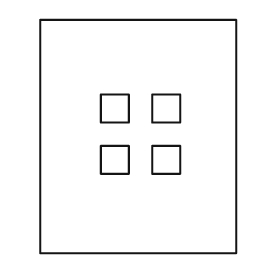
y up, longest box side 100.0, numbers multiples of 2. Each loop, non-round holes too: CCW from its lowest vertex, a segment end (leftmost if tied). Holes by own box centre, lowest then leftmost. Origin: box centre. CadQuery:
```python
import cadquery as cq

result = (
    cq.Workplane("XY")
    .moveTo(-42.0, -50.0)
    .lineTo(42.0, -50.0)
    .lineTo(42.0, 50.0)
    .lineTo(-42.0, 50.0)
    .close()
    .moveTo(-16.0, -16.0)
    .lineTo(-4.0, -16.0)
    .lineTo(-4.0, -4.0)
    .lineTo(-16.0, -4.0)
    .close()
    .moveTo(6.0, -16.0)
    .lineTo(18.0, -16.0)
    .lineTo(18.0, -4.0)
    .lineTo(6.0, -4.0)
    .close()
    .moveTo(-16.0, 6.0)
    .lineTo(-4.0, 6.0)
    .lineTo(-4.0, 18.0)
    .lineTo(-16.0, 18.0)
    .close()
    .moveTo(6.0, 6.0)
    .lineTo(18.0, 6.0)
    .lineTo(18.0, 18.0)
    .lineTo(6.0, 18.0)
    .close()
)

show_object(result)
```